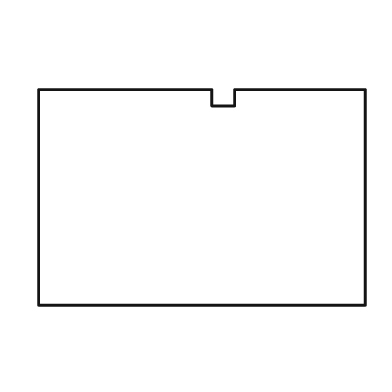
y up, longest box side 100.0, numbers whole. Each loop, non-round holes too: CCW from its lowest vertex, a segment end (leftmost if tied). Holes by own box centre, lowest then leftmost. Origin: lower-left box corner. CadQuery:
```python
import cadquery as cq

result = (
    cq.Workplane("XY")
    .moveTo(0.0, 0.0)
    .lineTo(100.0, 0.0)
    .lineTo(100.0, 66.0)
    .lineTo(60.0, 66.0)
    .lineTo(60.0, 61.0)
    .lineTo(53.0, 61.0)
    .lineTo(53.0, 66.0)
    .lineTo(0.0, 66.0)
    .close()
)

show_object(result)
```